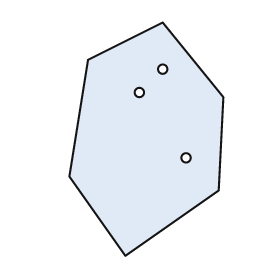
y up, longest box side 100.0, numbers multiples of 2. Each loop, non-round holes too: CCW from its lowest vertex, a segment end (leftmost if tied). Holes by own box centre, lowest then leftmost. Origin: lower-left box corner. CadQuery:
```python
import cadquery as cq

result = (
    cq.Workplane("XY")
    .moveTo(24.0, 0.0)
    .lineTo(64.0, 28.0)
    .lineTo(66.0, 68.0)
    .lineTo(40.0, 100.0)
    .lineTo(8.0, 84.0)
    .lineTo(0.0, 34.0)
    .close()
    .moveTo(50.0, 42.0)
    .circle(2.0)
    .moveTo(30.0, 70.0)
    .circle(2.0)
    .moveTo(40.0, 80.0)
    .circle(2.0)
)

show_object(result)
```